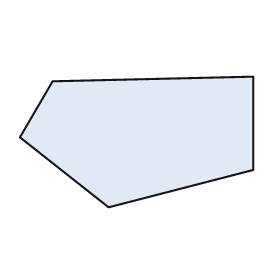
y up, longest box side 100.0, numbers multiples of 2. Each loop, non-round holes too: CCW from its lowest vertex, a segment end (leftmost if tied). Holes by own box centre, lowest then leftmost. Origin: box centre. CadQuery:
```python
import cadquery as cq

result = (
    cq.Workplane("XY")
    .moveTo(-12.0, -28.0)
    .lineTo(50.0, -12.0)
    .lineTo(50.0, 28.0)
    .lineTo(-36.0, 26.0)
    .lineTo(-50.0, 2.0)
    .close()
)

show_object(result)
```